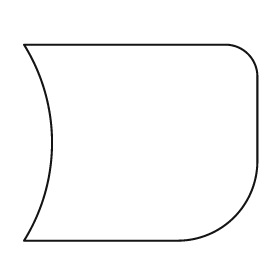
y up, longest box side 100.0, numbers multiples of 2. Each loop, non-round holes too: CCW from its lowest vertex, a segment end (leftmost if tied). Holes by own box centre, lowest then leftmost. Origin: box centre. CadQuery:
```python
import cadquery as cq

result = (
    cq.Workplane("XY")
    .moveTo(-50.0, -42.0)
    .lineTo(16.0, -42.0)
    .threePointArc((40.0, -32.0), (50.0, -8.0))
    .lineTo(50.0, 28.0)
    .threePointArc((46.0, 38.0), (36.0, 42.0))
    .lineTo(-50.0, 42.0)
    .threePointArc((-38.0, 0.0), (-50.0, -42.0))
    .close()
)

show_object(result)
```